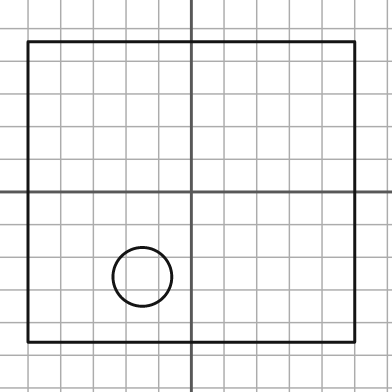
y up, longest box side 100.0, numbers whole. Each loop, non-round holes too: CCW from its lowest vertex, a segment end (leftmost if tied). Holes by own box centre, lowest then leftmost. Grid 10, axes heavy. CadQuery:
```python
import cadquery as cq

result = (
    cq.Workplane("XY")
    .moveTo(-50.0, -46.0)
    .lineTo(50.0, -46.0)
    .lineTo(50.0, 46.0)
    .lineTo(-50.0, 46.0)
    .close()
    .moveTo(-15.0, -26.0)
    .circle(9.0)
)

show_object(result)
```